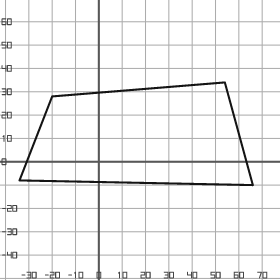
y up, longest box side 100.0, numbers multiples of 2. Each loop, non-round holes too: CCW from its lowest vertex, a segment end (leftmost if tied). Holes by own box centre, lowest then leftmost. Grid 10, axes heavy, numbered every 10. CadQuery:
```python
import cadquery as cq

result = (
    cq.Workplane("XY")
    .moveTo(66.0, -10.0)
    .lineTo(54.0, 34.0)
    .lineTo(-20.0, 28.0)
    .lineTo(-34.0, -8.0)
    .close()
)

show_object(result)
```